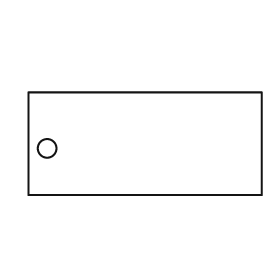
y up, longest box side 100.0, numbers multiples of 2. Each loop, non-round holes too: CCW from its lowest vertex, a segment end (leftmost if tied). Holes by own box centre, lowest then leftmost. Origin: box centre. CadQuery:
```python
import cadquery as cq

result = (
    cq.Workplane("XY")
    .moveTo(-50.0, -22.0)
    .lineTo(50.0, -22.0)
    .lineTo(50.0, 22.0)
    .lineTo(-50.0, 22.0)
    .close()
    .moveTo(-42.0, -2.0)
    .circle(4.0)
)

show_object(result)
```